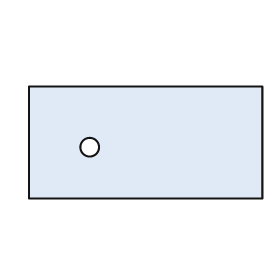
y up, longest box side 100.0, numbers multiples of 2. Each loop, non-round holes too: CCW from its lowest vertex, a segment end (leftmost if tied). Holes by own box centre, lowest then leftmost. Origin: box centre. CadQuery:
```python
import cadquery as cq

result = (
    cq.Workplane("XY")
    .moveTo(-50.0, -24.0)
    .lineTo(50.0, -24.0)
    .lineTo(50.0, 24.0)
    .lineTo(-50.0, 24.0)
    .close()
    .moveTo(-24.0, -2.0)
    .circle(4.0)
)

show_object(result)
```